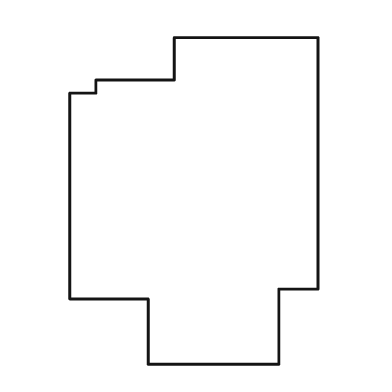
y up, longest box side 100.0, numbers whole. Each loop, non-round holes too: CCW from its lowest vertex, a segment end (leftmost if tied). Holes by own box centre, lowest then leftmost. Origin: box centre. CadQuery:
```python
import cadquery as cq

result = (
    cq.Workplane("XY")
    .moveTo(-14.0, -50.0)
    .lineTo(26.0, -50.0)
    .lineTo(26.0, -27.0)
    .lineTo(38.0, -27.0)
    .lineTo(38.0, 50.0)
    .lineTo(-6.0, 50.0)
    .lineTo(-6.0, 37.0)
    .lineTo(-30.0, 37.0)
    .lineTo(-30.0, 33.0)
    .lineTo(-38.0, 33.0)
    .lineTo(-38.0, -30.0)
    .lineTo(-14.0, -30.0)
    .close()
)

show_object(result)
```